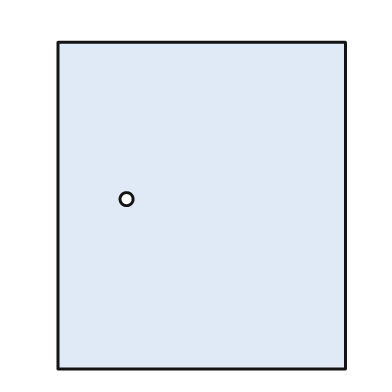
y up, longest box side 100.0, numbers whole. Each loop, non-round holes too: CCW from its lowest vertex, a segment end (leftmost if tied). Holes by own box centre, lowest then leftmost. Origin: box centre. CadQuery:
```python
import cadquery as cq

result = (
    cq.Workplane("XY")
    .moveTo(-44.0, -50.0)
    .lineTo(44.0, -50.0)
    .lineTo(44.0, 50.0)
    .lineTo(-44.0, 50.0)
    .close()
    .moveTo(-23.0, 2.0)
    .circle(2.0)
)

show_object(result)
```